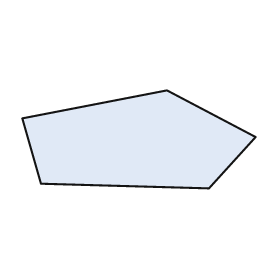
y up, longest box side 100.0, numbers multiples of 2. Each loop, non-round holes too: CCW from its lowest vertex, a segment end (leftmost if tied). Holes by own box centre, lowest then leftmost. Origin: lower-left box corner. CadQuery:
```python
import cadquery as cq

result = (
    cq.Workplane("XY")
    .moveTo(80.0, 0.0)
    .lineTo(100.0, 22.0)
    .lineTo(62.0, 42.0)
    .lineTo(0.0, 30.0)
    .lineTo(8.0, 2.0)
    .close()
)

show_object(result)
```